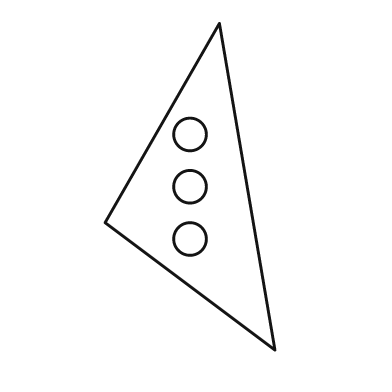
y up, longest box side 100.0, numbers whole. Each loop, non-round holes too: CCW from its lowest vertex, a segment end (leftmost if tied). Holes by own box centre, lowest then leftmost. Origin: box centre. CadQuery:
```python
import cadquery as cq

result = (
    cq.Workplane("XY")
    .moveTo(26.0, -50.0)
    .lineTo(9.0, 50.0)
    .lineTo(-26.0, -11.0)
    .close()
    .moveTo(0.0, -16.0)
    .circle(5.0)
    .moveTo(0.0, 0.0)
    .circle(5.0)
    .moveTo(0.0, 16.0)
    .circle(5.0)
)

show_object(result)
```